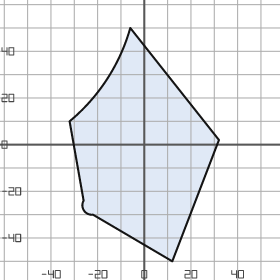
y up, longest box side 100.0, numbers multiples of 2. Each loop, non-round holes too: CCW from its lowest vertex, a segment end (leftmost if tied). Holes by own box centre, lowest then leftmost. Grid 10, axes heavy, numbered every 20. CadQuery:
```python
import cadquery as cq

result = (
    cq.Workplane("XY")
    .moveTo(12.0, -50.0)
    .lineTo(32.0, 2.0)
    .lineTo(-6.0, 50.0)
    .threePointArc((-16.0, 28.0), (-32.0, 10.0))
    .lineTo(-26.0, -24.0)
    .threePointArc((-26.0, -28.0), (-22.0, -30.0))
    .close()
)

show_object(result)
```